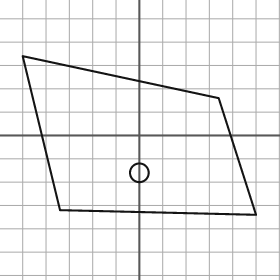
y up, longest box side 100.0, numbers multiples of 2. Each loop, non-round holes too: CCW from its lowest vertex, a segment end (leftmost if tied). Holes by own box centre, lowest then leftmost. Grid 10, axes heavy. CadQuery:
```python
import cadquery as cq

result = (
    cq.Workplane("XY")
    .moveTo(50.0, -34.0)
    .lineTo(34.0, 16.0)
    .lineTo(-50.0, 34.0)
    .lineTo(-34.0, -32.0)
    .close()
    .moveTo(0.0, -16.0)
    .circle(4.0)
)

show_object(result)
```